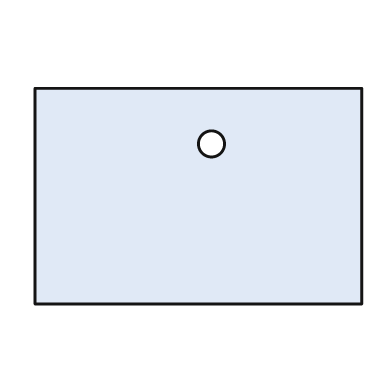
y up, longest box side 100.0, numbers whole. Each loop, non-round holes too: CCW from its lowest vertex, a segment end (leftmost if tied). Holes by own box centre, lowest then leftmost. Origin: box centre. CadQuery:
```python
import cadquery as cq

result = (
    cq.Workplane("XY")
    .moveTo(-50.0, -33.0)
    .lineTo(50.0, -33.0)
    .lineTo(50.0, 33.0)
    .lineTo(-50.0, 33.0)
    .close()
    .moveTo(4.0, 16.0)
    .circle(4.0)
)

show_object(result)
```